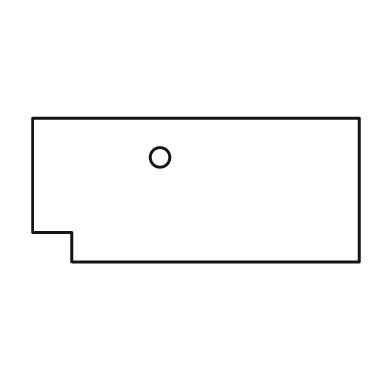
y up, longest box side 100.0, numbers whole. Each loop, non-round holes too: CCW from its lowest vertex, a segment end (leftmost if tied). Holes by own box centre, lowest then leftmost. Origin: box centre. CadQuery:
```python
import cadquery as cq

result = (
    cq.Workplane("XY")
    .moveTo(-38.0, -22.0)
    .lineTo(50.0, -22.0)
    .lineTo(50.0, 22.0)
    .lineTo(-50.0, 22.0)
    .lineTo(-50.0, -13.0)
    .lineTo(-38.0, -13.0)
    .close()
    .moveTo(-11.0, 10.0)
    .circle(3.0)
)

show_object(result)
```